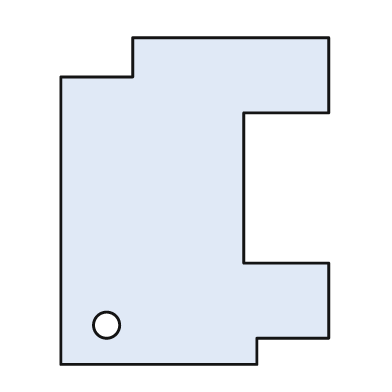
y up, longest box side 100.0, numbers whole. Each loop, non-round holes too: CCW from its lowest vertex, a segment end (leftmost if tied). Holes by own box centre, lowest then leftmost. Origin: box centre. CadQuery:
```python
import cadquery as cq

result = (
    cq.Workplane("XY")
    .moveTo(-41.0, -50.0)
    .lineTo(19.0, -50.0)
    .lineTo(19.0, -42.0)
    .lineTo(41.0, -42.0)
    .lineTo(41.0, -19.0)
    .lineTo(15.0, -19.0)
    .lineTo(15.0, 27.0)
    .lineTo(41.0, 27.0)
    .lineTo(41.0, 50.0)
    .lineTo(-19.0, 50.0)
    .lineTo(-19.0, 38.0)
    .lineTo(-41.0, 38.0)
    .close()
    .moveTo(-27.0, -38.0)
    .circle(4.0)
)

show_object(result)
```